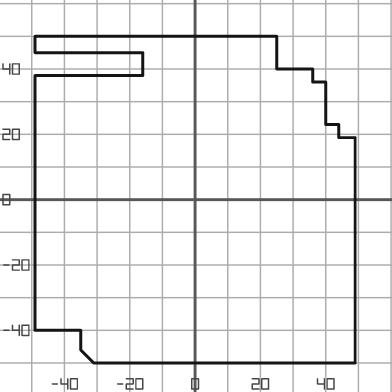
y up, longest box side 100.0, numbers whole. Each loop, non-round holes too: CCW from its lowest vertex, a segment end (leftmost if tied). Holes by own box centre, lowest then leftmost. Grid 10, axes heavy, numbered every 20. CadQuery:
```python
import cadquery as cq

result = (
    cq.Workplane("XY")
    .moveTo(-31.0, -50.0)
    .lineTo(49.0, -50.0)
    .lineTo(49.0, 19.0)
    .lineTo(44.0, 19.0)
    .lineTo(44.0, 23.0)
    .lineTo(40.0, 23.0)
    .lineTo(40.0, 36.0)
    .lineTo(36.0, 36.0)
    .lineTo(36.0, 40.0)
    .lineTo(25.0, 40.0)
    .lineTo(25.0, 50.0)
    .lineTo(-49.0, 50.0)
    .lineTo(-49.0, 45.0)
    .lineTo(-16.0, 45.0)
    .lineTo(-16.0, 38.0)
    .lineTo(-49.0, 38.0)
    .lineTo(-49.0, -40.0)
    .lineTo(-35.0, -40.0)
    .lineTo(-35.0, -46.0)
    .close()
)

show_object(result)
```